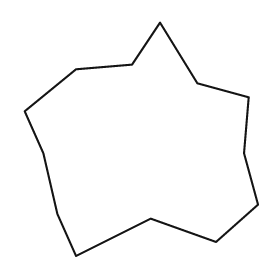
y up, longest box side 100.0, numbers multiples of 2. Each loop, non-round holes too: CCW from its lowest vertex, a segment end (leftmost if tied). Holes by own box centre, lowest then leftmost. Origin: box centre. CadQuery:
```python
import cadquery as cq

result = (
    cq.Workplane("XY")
    .moveTo(-28.0, -50.0)
    .lineTo(4.0, -34.0)
    .lineTo(32.0, -44.0)
    .lineTo(50.0, -28.0)
    .lineTo(44.0, -6.0)
    .lineTo(46.0, 18.0)
    .lineTo(24.0, 24.0)
    .lineTo(8.0, 50.0)
    .lineTo(-4.0, 32.0)
    .lineTo(-28.0, 30.0)
    .lineTo(-50.0, 12.0)
    .lineTo(-42.0, -6.0)
    .lineTo(-36.0, -32.0)
    .close()
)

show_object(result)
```